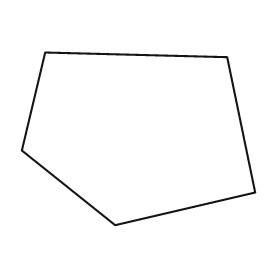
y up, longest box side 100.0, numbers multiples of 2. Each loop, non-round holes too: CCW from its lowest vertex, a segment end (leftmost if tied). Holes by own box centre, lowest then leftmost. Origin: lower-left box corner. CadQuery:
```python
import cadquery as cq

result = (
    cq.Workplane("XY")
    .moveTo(40.0, 0.0)
    .lineTo(100.0, 14.0)
    .lineTo(88.0, 72.0)
    .lineTo(10.0, 74.0)
    .lineTo(0.0, 32.0)
    .close()
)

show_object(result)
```